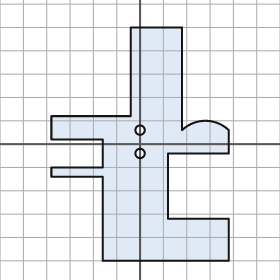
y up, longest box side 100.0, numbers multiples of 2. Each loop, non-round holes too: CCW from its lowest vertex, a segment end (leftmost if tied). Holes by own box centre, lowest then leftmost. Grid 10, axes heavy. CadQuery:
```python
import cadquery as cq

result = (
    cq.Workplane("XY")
    .moveTo(-16.0, -50.0)
    .lineTo(38.0, -50.0)
    .lineTo(38.0, -32.0)
    .lineTo(12.0, -32.0)
    .lineTo(12.0, -4.0)
    .lineTo(38.0, -4.0)
    .lineTo(38.0, 6.0)
    .threePointArc((28.0, 10.0), (18.0, 6.0))
    .lineTo(18.0, 50.0)
    .lineTo(-4.0, 50.0)
    .lineTo(-4.0, 12.0)
    .lineTo(-38.0, 12.0)
    .lineTo(-38.0, 2.0)
    .lineTo(-16.0, 2.0)
    .lineTo(-16.0, -10.0)
    .lineTo(-38.0, -10.0)
    .lineTo(-38.0, -14.0)
    .lineTo(-16.0, -14.0)
    .close()
    .moveTo(0.0, -4.0)
    .circle(2.0)
    .moveTo(0.0, 6.0)
    .circle(2.0)
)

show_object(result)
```